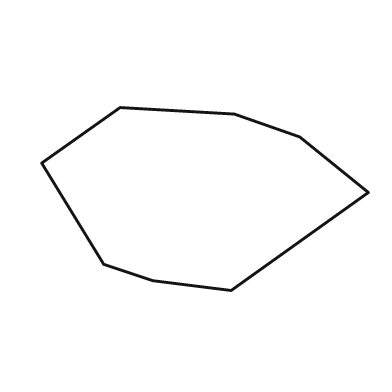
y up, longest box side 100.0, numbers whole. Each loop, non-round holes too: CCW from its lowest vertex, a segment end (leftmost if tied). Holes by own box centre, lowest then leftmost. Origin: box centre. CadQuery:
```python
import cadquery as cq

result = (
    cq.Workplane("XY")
    .moveTo(8.0, -28.0)
    .lineTo(50.0, 2.0)
    .lineTo(29.0, 19.0)
    .lineTo(9.0, 26.0)
    .lineTo(-26.0, 28.0)
    .lineTo(-50.0, 11.0)
    .lineTo(-31.0, -20.0)
    .lineTo(-16.0, -25.0)
    .close()
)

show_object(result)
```